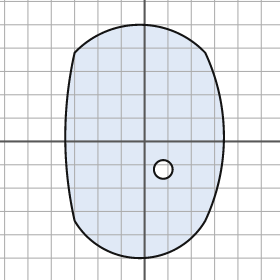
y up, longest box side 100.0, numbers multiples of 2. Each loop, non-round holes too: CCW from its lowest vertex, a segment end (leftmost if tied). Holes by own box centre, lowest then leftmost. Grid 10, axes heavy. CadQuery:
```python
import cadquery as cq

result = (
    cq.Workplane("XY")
    .moveTo(-30.0, -34.0)
    .threePointArc((-2.0, -50.0), (26.0, -34.0))
    .threePointArc((34.0, 2.0), (26.0, 38.0))
    .threePointArc((-2.0, 50.0), (-30.0, 38.0))
    .threePointArc((-34.0, 2.0), (-30.0, -34.0))
    .close()
    .moveTo(8.0, -12.0)
    .circle(4.0)
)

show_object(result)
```